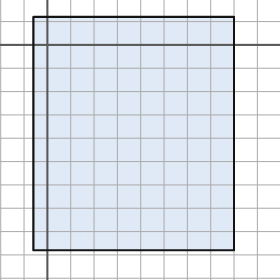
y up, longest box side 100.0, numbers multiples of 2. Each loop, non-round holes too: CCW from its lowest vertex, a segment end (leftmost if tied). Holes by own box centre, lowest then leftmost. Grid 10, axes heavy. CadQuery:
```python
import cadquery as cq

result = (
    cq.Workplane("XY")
    .moveTo(-6.0, -88.0)
    .lineTo(80.0, -88.0)
    .lineTo(80.0, 12.0)
    .lineTo(-6.0, 12.0)
    .close()
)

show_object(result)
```